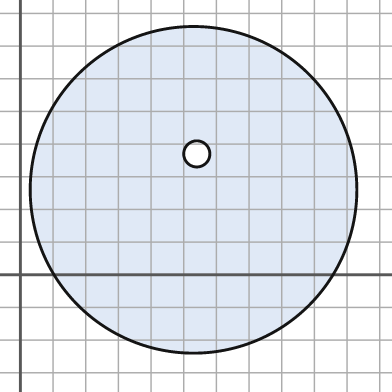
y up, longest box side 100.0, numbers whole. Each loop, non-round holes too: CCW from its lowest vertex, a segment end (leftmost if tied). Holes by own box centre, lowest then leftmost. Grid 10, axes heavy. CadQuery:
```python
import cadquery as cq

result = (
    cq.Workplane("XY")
    .moveTo(53.0, 26.0)
    .circle(50.0)
    .moveTo(54.0, 37.0)
    .circle(4.0)
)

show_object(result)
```